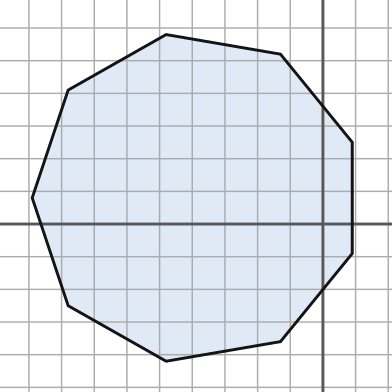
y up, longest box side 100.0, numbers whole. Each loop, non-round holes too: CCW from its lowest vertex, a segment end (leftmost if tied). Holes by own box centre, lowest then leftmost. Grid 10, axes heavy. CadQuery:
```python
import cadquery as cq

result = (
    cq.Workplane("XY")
    .moveTo(-48.0, -42.0)
    .lineTo(-13.0, -36.0)
    .lineTo(9.0, -9.0)
    .lineTo(9.0, 25.0)
    .lineTo(-13.0, 52.0)
    .lineTo(-48.0, 58.0)
    .lineTo(-78.0, 41.0)
    .lineTo(-89.0, 8.0)
    .lineTo(-78.0, -25.0)
    .close()
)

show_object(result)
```